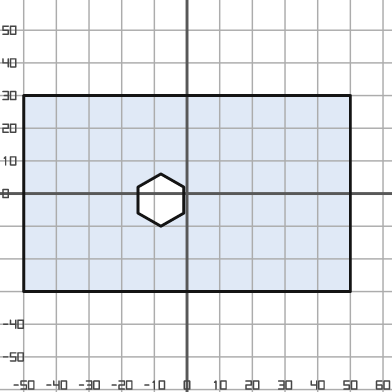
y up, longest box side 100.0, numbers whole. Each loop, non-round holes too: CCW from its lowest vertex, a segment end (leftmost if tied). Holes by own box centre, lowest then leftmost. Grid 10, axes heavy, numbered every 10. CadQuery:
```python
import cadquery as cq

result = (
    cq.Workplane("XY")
    .moveTo(-50.0, -30.0)
    .lineTo(50.0, -30.0)
    .lineTo(50.0, 30.0)
    .lineTo(-50.0, 30.0)
    .close()
    .moveTo(-8.0, -10.0)
    .lineTo(-1.0, -6.0)
    .lineTo(-1.0, 2.0)
    .lineTo(-8.0, 6.0)
    .lineTo(-15.0, 2.0)
    .lineTo(-15.0, -6.0)
    .close()
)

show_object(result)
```